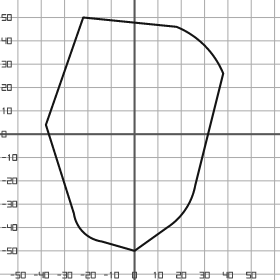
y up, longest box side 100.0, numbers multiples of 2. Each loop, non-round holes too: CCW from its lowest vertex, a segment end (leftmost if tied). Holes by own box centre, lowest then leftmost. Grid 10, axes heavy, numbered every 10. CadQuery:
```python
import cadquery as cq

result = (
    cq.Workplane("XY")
    .moveTo(0.0, -50.0)
    .lineTo(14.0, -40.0)
    .threePointArc((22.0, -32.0), (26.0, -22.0))
    .lineTo(38.0, 26.0)
    .threePointArc((30.0, 38.0), (18.0, 46.0))
    .lineTo(-22.0, 50.0)
    .lineTo(-38.0, 4.0)
    .lineTo(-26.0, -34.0)
    .threePointArc((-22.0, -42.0), (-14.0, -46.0))
    .close()
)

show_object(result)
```